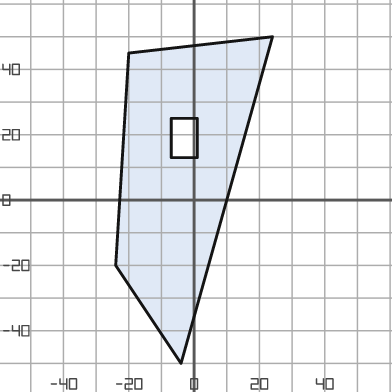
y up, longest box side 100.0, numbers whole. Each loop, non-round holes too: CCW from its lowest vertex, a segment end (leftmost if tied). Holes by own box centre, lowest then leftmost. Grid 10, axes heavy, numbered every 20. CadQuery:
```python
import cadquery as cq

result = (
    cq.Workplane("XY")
    .moveTo(-4.0, -50.0)
    .lineTo(24.0, 50.0)
    .lineTo(-20.0, 45.0)
    .lineTo(-24.0, -20.0)
    .close()
    .moveTo(-7.0, 13.0)
    .lineTo(1.0, 13.0)
    .lineTo(1.0, 25.0)
    .lineTo(-7.0, 25.0)
    .close()
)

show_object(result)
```